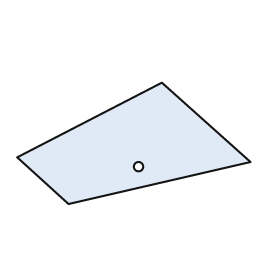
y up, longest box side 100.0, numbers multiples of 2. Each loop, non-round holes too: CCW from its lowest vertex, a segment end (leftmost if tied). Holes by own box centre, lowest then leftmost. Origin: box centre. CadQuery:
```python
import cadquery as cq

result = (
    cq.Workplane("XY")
    .moveTo(-28.0, -26.0)
    .lineTo(50.0, -8.0)
    .lineTo(12.0, 26.0)
    .lineTo(-50.0, -6.0)
    .close()
    .moveTo(2.0, -10.0)
    .circle(2.0)
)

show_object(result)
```